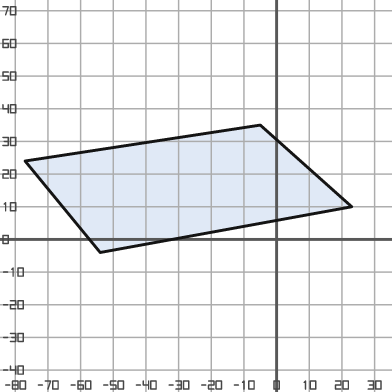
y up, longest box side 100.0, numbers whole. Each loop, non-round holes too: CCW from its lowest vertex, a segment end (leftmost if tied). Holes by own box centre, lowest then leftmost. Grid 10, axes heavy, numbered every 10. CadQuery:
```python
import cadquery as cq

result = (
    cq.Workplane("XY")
    .moveTo(-54.0, -4.0)
    .lineTo(23.0, 10.0)
    .lineTo(-5.0, 35.0)
    .lineTo(-77.0, 24.0)
    .close()
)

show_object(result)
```